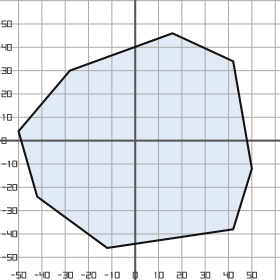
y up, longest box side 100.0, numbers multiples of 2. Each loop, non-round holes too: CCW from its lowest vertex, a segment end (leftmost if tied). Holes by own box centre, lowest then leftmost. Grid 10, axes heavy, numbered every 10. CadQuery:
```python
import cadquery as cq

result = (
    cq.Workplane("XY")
    .moveTo(-12.0, -46.0)
    .lineTo(42.0, -38.0)
    .lineTo(50.0, -12.0)
    .lineTo(42.0, 34.0)
    .lineTo(16.0, 46.0)
    .lineTo(-28.0, 30.0)
    .lineTo(-50.0, 4.0)
    .lineTo(-42.0, -24.0)
    .close()
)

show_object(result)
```